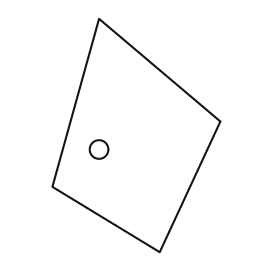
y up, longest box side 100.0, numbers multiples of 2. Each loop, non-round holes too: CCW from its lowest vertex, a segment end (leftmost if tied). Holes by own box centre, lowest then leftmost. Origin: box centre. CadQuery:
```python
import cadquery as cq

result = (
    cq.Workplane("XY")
    .moveTo(10.0, -50.0)
    .lineTo(36.0, 6.0)
    .lineTo(-16.0, 50.0)
    .lineTo(-36.0, -22.0)
    .close()
    .moveTo(-16.0, -6.0)
    .circle(4.0)
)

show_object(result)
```